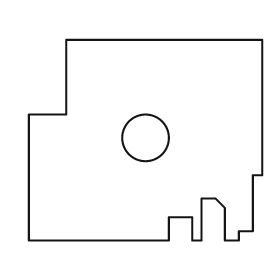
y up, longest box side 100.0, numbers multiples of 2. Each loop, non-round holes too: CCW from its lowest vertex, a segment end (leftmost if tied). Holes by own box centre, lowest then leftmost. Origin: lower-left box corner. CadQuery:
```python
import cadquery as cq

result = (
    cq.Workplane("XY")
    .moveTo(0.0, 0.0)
    .lineTo(60.0, 0.0)
    .lineTo(60.0, 10.0)
    .lineTo(70.0, 10.0)
    .lineTo(70.0, 0.0)
    .lineTo(74.0, 0.0)
    .lineTo(74.0, 18.0)
    .lineTo(80.0, 18.0)
    .lineTo(84.0, 14.0)
    .lineTo(84.0, 0.0)
    .lineTo(90.0, 0.0)
    .lineTo(90.0, 4.0)
    .lineTo(96.0, 4.0)
    .lineTo(96.0, 28.0)
    .lineTo(100.0, 28.0)
    .lineTo(100.0, 86.0)
    .lineTo(16.0, 86.0)
    .lineTo(16.0, 54.0)
    .lineTo(0.0, 54.0)
    .close()
    .moveTo(50.0, 44.0)
    .circle(10.0)
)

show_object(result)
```